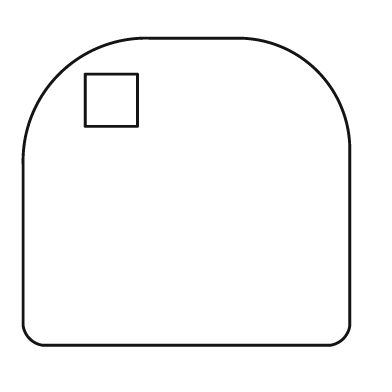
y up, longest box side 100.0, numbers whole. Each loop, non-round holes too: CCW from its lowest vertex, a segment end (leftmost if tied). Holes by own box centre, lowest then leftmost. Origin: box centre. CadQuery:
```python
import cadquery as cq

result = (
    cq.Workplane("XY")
    .moveTo(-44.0, -47.0)
    .lineTo(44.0, -47.0)
    .threePointArc((48.0, -45.0), (50.0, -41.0))
    .lineTo(50.0, 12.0)
    .threePointArc((40.0, 37.0), (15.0, 47.0))
    .lineTo(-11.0, 47.0)
    .threePointArc((-39.0, 36.0), (-50.0, 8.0))
    .lineTo(-50.0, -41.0)
    .threePointArc((-48.0, -45.0), (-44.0, -47.0))
    .close()
    .moveTo(-31.0, 20.0)
    .lineTo(-15.0, 20.0)
    .lineTo(-15.0, 36.0)
    .lineTo(-31.0, 36.0)
    .close()
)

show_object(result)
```